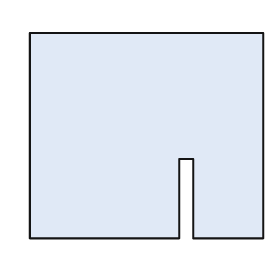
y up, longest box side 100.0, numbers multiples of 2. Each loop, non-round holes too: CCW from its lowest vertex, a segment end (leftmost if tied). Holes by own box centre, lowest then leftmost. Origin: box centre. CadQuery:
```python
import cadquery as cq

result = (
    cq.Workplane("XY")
    .moveTo(-50.0, -44.0)
    .lineTo(14.0, -44.0)
    .lineTo(14.0, -10.0)
    .lineTo(20.0, -10.0)
    .lineTo(20.0, -44.0)
    .lineTo(50.0, -44.0)
    .lineTo(50.0, 44.0)
    .lineTo(-50.0, 44.0)
    .close()
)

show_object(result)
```